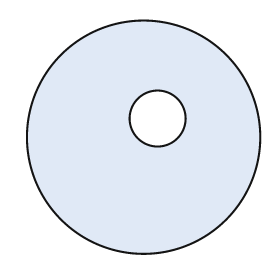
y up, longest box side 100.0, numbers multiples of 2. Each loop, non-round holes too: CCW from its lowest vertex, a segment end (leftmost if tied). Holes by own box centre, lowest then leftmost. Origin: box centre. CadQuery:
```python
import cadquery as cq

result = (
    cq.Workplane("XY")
    .moveTo(0.0, 0.0)
    .circle(50.0)
    .moveTo(6.0, 8.0)
    .circle(12.0)
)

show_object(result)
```